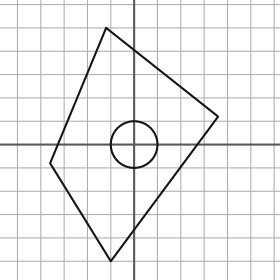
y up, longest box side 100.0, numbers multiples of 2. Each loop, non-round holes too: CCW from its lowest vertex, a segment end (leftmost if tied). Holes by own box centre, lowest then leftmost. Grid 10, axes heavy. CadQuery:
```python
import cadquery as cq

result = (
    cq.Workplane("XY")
    .moveTo(-10.0, -50.0)
    .lineTo(36.0, 12.0)
    .lineTo(-12.0, 50.0)
    .lineTo(-36.0, -8.0)
    .close()
    .moveTo(0.0, 0.0)
    .circle(10.0)
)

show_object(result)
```